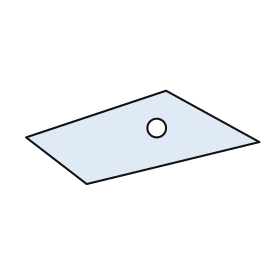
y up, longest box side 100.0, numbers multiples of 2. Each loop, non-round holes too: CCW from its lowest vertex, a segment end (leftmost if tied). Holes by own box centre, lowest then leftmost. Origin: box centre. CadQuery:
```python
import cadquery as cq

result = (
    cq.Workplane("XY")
    .moveTo(-24.0, -20.0)
    .lineTo(50.0, -2.0)
    .lineTo(10.0, 20.0)
    .lineTo(-50.0, 0.0)
    .close()
    .moveTo(6.0, 4.0)
    .circle(4.0)
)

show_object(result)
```